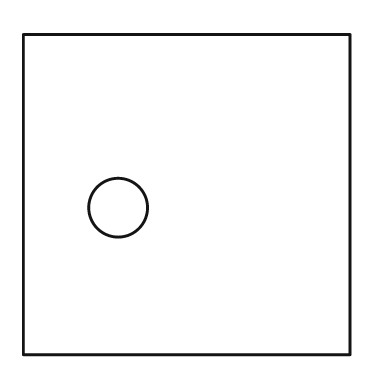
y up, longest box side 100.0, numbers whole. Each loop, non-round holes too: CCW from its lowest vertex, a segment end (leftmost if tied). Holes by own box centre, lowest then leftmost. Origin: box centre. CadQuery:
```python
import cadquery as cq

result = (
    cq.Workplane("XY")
    .moveTo(-50.0, -49.0)
    .lineTo(50.0, -49.0)
    .lineTo(50.0, 49.0)
    .lineTo(-50.0, 49.0)
    .close()
    .moveTo(-21.0, -4.0)
    .circle(9.0)
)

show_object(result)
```